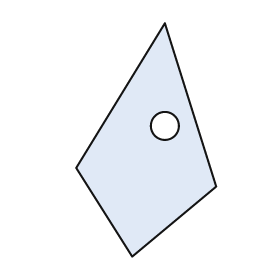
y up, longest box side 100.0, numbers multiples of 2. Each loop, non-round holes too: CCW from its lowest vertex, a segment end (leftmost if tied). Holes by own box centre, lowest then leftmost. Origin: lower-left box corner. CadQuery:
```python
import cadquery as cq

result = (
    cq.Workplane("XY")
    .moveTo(24.0, 0.0)
    .lineTo(60.0, 30.0)
    .lineTo(38.0, 100.0)
    .lineTo(0.0, 38.0)
    .close()
    .moveTo(38.0, 56.0)
    .circle(6.0)
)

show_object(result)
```